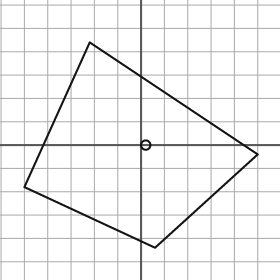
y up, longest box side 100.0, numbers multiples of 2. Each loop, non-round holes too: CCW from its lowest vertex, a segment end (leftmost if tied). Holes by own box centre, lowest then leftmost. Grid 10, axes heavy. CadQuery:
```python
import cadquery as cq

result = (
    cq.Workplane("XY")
    .moveTo(6.0, -44.0)
    .lineTo(50.0, -4.0)
    .lineTo(-22.0, 44.0)
    .lineTo(-50.0, -18.0)
    .close()
    .moveTo(2.0, 0.0)
    .circle(2.0)
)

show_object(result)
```